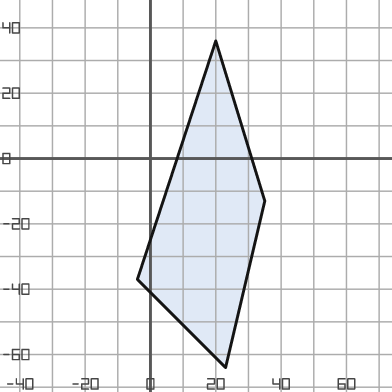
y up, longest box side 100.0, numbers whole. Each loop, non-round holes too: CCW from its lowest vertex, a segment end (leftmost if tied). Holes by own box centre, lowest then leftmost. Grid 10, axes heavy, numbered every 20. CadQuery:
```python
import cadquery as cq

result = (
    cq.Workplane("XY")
    .moveTo(23.0, -64.0)
    .lineTo(35.0, -13.0)
    .lineTo(20.0, 36.0)
    .lineTo(-4.0, -37.0)
    .close()
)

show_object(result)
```